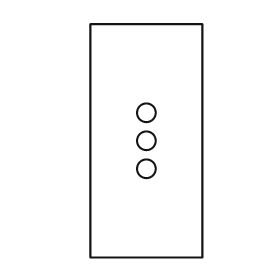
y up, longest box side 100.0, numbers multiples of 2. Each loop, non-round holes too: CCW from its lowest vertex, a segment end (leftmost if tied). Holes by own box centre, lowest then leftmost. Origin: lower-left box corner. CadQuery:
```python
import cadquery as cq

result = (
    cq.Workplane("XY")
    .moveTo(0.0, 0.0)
    .lineTo(48.0, 0.0)
    .lineTo(48.0, 100.0)
    .lineTo(0.0, 100.0)
    .close()
    .moveTo(24.0, 38.0)
    .circle(4.0)
    .moveTo(24.0, 50.0)
    .circle(4.0)
    .moveTo(24.0, 62.0)
    .circle(4.0)
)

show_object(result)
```